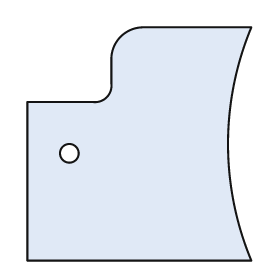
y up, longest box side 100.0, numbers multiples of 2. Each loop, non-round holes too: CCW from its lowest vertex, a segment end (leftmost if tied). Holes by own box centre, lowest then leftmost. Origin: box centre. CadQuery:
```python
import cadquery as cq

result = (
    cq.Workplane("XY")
    .moveTo(-48.0, -50.0)
    .lineTo(48.0, -50.0)
    .threePointArc((38.0, 0.0), (48.0, 50.0))
    .lineTo(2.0, 50.0)
    .threePointArc((-8.0, 46.0), (-12.0, 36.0))
    .lineTo(-12.0, 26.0)
    .threePointArc((-14.0, 20.0), (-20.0, 18.0))
    .lineTo(-48.0, 18.0)
    .close()
    .moveTo(-30.0, -4.0)
    .circle(4.0)
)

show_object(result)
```